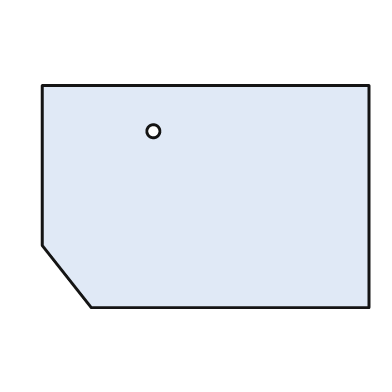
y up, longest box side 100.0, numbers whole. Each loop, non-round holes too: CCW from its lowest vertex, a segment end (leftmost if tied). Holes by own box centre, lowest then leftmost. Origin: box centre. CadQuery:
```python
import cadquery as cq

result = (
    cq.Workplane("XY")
    .moveTo(-35.0, -34.0)
    .lineTo(50.0, -34.0)
    .lineTo(50.0, 34.0)
    .lineTo(-50.0, 34.0)
    .lineTo(-50.0, -15.0)
    .close()
    .moveTo(-16.0, 20.0)
    .circle(2.0)
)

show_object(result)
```